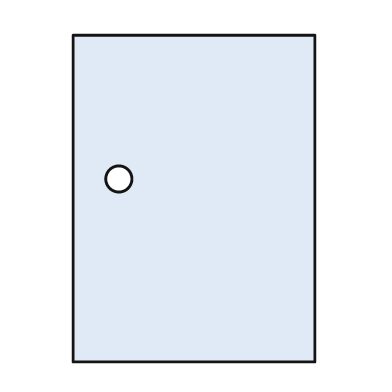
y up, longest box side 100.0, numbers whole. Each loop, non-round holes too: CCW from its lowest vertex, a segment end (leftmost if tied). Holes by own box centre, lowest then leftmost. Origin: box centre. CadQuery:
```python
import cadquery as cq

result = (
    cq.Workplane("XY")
    .moveTo(-37.0, -50.0)
    .lineTo(37.0, -50.0)
    .lineTo(37.0, 50.0)
    .lineTo(-37.0, 50.0)
    .close()
    .moveTo(-23.0, 6.0)
    .circle(4.0)
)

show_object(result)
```